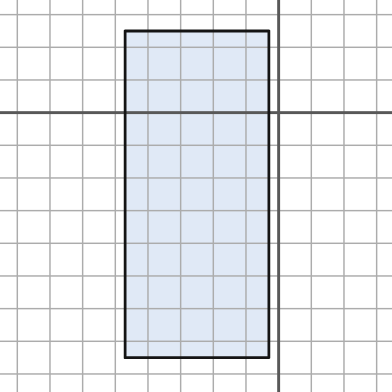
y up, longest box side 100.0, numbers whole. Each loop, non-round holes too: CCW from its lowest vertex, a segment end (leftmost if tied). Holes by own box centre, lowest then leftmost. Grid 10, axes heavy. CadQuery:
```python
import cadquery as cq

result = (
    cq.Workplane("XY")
    .moveTo(-47.0, -75.0)
    .lineTo(-3.0, -75.0)
    .lineTo(-3.0, 25.0)
    .lineTo(-47.0, 25.0)
    .close()
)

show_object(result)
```